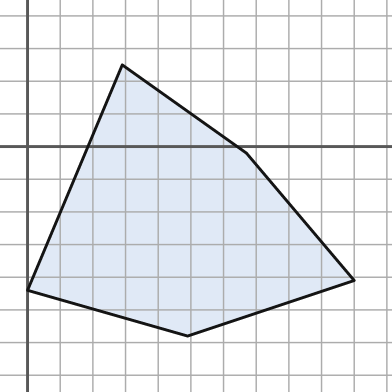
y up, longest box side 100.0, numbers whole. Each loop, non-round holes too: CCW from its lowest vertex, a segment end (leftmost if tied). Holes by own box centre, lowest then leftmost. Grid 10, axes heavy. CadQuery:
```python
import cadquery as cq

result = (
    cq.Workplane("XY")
    .moveTo(49.0, -58.0)
    .lineTo(100.0, -41.0)
    .lineTo(67.0, -2.0)
    .lineTo(29.0, 25.0)
    .lineTo(0.0, -44.0)
    .close()
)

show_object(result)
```